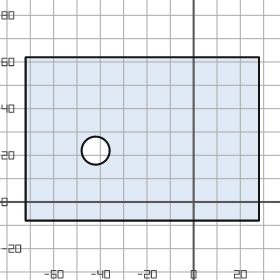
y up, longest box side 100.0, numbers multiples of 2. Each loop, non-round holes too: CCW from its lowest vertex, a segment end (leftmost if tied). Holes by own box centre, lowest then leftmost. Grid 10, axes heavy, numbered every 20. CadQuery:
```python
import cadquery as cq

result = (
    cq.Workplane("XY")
    .moveTo(-72.0, -8.0)
    .lineTo(28.0, -8.0)
    .lineTo(28.0, 62.0)
    .lineTo(-72.0, 62.0)
    .close()
    .moveTo(-42.0, 22.0)
    .circle(6.0)
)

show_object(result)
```